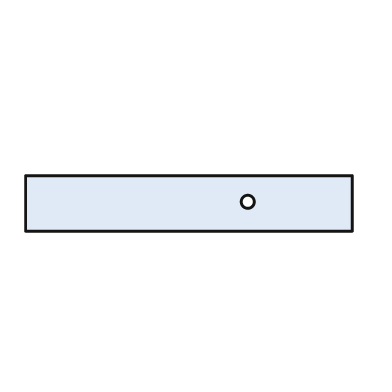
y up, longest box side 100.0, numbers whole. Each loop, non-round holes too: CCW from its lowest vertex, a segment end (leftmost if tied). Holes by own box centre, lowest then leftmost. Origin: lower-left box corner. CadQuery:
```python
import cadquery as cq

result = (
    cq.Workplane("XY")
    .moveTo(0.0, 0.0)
    .lineTo(100.0, 0.0)
    .lineTo(100.0, 17.0)
    .lineTo(0.0, 17.0)
    .close()
    .moveTo(68.0, 9.0)
    .circle(2.0)
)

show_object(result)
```